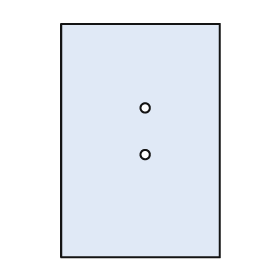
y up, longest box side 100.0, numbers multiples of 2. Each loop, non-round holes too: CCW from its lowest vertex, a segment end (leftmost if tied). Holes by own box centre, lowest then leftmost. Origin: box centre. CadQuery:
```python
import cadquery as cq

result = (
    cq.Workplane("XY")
    .moveTo(-34.0, -50.0)
    .lineTo(34.0, -50.0)
    .lineTo(34.0, 50.0)
    .lineTo(-34.0, 50.0)
    .close()
    .moveTo(2.0, -6.0)
    .circle(2.0)
    .moveTo(2.0, 14.0)
    .circle(2.0)
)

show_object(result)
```